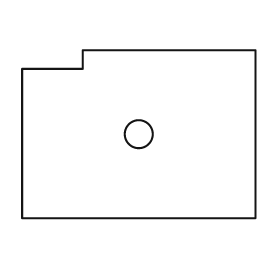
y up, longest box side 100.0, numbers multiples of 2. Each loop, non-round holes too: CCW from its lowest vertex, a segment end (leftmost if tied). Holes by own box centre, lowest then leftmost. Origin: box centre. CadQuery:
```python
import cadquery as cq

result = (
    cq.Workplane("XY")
    .moveTo(-50.0, -36.0)
    .lineTo(50.0, -36.0)
    .lineTo(50.0, 36.0)
    .lineTo(-24.0, 36.0)
    .lineTo(-24.0, 28.0)
    .lineTo(-50.0, 28.0)
    .close()
    .moveTo(0.0, 0.0)
    .circle(6.0)
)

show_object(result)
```